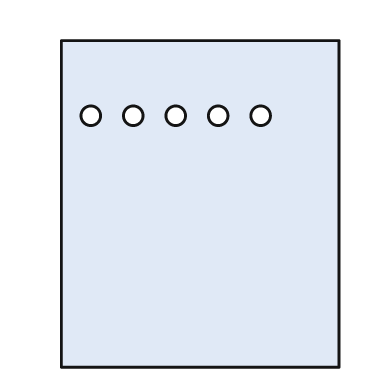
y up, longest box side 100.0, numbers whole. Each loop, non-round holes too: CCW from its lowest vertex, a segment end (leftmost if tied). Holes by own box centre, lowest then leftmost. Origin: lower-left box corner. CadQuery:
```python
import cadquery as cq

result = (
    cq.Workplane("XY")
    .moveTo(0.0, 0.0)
    .lineTo(85.0, 0.0)
    .lineTo(85.0, 100.0)
    .lineTo(0.0, 100.0)
    .close()
    .moveTo(9.0, 77.0)
    .circle(3.0)
    .moveTo(22.0, 77.0)
    .circle(3.0)
    .moveTo(35.0, 77.0)
    .circle(3.0)
    .moveTo(48.0, 77.0)
    .circle(3.0)
    .moveTo(61.0, 77.0)
    .circle(3.0)
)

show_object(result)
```